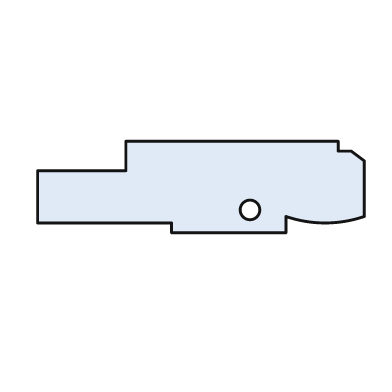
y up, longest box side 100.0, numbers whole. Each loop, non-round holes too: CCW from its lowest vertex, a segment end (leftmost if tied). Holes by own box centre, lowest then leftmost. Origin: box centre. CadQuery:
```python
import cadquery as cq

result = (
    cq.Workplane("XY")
    .moveTo(-9.0, -14.0)
    .lineTo(26.0, -14.0)
    .lineTo(26.0, -9.0)
    .threePointArc((38.0, -11.0), (50.0, -9.0))
    .lineTo(50.0, 8.0)
    .lineTo(46.0, 11.0)
    .lineTo(42.0, 11.0)
    .lineTo(42.0, 14.0)
    .lineTo(-23.0, 14.0)
    .lineTo(-23.0, 5.0)
    .lineTo(-50.0, 5.0)
    .lineTo(-50.0, -11.0)
    .lineTo(-9.0, -11.0)
    .close()
    .moveTo(15.0, -7.0)
    .circle(3.0)
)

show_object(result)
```